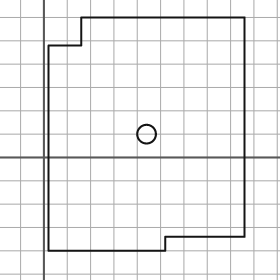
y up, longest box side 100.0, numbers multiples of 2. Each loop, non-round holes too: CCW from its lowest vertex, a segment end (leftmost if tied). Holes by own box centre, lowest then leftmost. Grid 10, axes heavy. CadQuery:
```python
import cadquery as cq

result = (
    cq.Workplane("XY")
    .moveTo(2.0, -40.0)
    .lineTo(52.0, -40.0)
    .lineTo(52.0, -34.0)
    .lineTo(86.0, -34.0)
    .lineTo(86.0, 60.0)
    .lineTo(16.0, 60.0)
    .lineTo(16.0, 48.0)
    .lineTo(2.0, 48.0)
    .close()
    .moveTo(44.0, 10.0)
    .circle(4.0)
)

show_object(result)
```